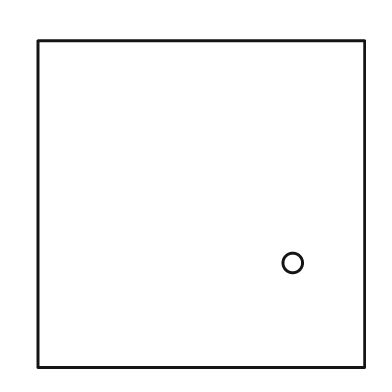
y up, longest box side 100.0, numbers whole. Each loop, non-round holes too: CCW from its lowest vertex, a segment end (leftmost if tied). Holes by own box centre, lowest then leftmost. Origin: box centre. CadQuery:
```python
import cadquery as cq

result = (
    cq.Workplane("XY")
    .moveTo(-50.0, -50.0)
    .lineTo(50.0, -50.0)
    .lineTo(50.0, 50.0)
    .lineTo(-50.0, 50.0)
    .close()
    .moveTo(28.0, -18.0)
    .circle(3.0)
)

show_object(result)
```